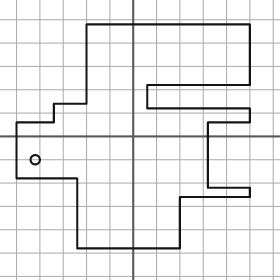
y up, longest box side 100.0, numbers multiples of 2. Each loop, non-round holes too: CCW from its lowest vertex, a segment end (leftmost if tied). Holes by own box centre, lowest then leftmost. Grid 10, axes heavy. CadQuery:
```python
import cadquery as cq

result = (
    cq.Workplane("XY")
    .moveTo(-24.0, -48.0)
    .lineTo(20.0, -48.0)
    .lineTo(20.0, -26.0)
    .lineTo(50.0, -26.0)
    .lineTo(50.0, -22.0)
    .lineTo(32.0, -22.0)
    .lineTo(32.0, 6.0)
    .lineTo(50.0, 6.0)
    .lineTo(50.0, 12.0)
    .lineTo(6.0, 12.0)
    .lineTo(6.0, 22.0)
    .lineTo(50.0, 22.0)
    .lineTo(50.0, 48.0)
    .lineTo(-20.0, 48.0)
    .lineTo(-20.0, 14.0)
    .lineTo(-34.0, 14.0)
    .lineTo(-34.0, 6.0)
    .lineTo(-50.0, 6.0)
    .lineTo(-50.0, -18.0)
    .lineTo(-24.0, -18.0)
    .close()
    .moveTo(-42.0, -10.0)
    .circle(2.0)
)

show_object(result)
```